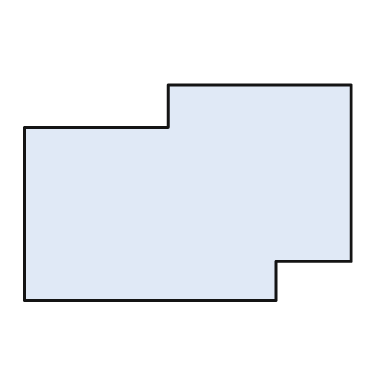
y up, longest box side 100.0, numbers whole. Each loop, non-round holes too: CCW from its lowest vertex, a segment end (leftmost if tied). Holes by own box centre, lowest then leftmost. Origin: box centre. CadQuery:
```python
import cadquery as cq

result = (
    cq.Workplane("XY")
    .moveTo(-50.0, -33.0)
    .lineTo(27.0, -33.0)
    .lineTo(27.0, -21.0)
    .lineTo(50.0, -21.0)
    .lineTo(50.0, 33.0)
    .lineTo(-6.0, 33.0)
    .lineTo(-6.0, 20.0)
    .lineTo(-50.0, 20.0)
    .close()
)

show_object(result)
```